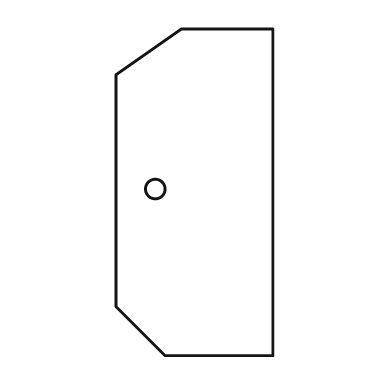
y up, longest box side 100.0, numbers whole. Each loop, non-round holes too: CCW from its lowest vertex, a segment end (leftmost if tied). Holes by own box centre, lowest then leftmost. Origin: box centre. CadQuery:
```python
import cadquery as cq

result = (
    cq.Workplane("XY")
    .moveTo(-9.0, -50.0)
    .lineTo(24.0, -50.0)
    .lineTo(24.0, 50.0)
    .lineTo(-4.0, 50.0)
    .lineTo(-24.0, 36.0)
    .lineTo(-24.0, -35.0)
    .close()
    .moveTo(-12.0, 1.0)
    .circle(3.0)
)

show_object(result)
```